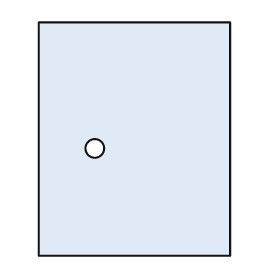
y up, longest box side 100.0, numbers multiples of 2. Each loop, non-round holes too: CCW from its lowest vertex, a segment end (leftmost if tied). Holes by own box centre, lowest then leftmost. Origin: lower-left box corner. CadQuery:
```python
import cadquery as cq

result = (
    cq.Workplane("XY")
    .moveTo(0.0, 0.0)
    .lineTo(82.0, 0.0)
    .lineTo(82.0, 100.0)
    .lineTo(0.0, 100.0)
    .close()
    .moveTo(24.0, 46.0)
    .circle(4.0)
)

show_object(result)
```